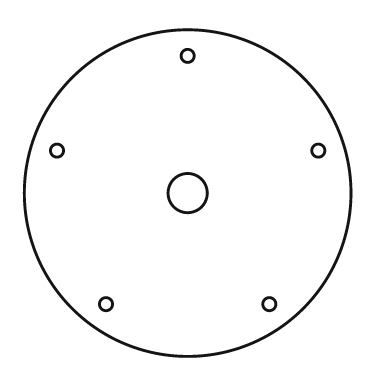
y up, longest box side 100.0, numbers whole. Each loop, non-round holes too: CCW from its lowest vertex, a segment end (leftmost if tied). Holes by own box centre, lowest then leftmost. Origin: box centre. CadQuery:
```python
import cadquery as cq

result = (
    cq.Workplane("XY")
    .moveTo(0.0, 0.0)
    .circle(50.0)
    .moveTo(-25.0, -34.0)
    .circle(2.0)
    .moveTo(25.0, -34.0)
    .circle(2.0)
    .moveTo(0.0, 0.0)
    .circle(6.0)
    .moveTo(-40.0, 13.0)
    .circle(2.0)
    .moveTo(40.0, 13.0)
    .circle(2.0)
    .moveTo(0.0, 42.0)
    .circle(2.0)
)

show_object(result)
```